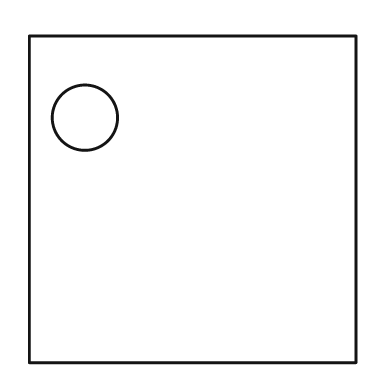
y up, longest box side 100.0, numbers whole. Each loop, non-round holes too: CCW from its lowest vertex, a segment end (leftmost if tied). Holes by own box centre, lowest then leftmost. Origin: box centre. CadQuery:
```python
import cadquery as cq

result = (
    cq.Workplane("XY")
    .moveTo(-50.0, -50.0)
    .lineTo(50.0, -50.0)
    .lineTo(50.0, 50.0)
    .lineTo(-50.0, 50.0)
    .close()
    .moveTo(-33.0, 25.0)
    .circle(10.0)
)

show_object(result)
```